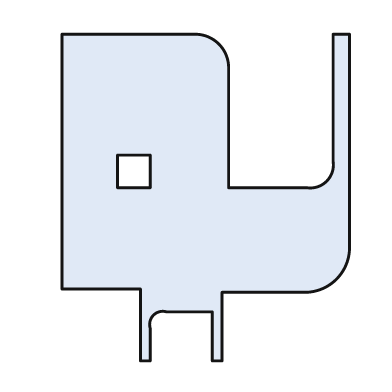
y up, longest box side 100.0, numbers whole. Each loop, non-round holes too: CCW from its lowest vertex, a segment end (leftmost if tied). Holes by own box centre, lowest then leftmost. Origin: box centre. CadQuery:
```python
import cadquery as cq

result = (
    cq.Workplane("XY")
    .moveTo(-20.0, -50.0)
    .lineTo(-17.0, -50.0)
    .lineTo(-17.0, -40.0)
    .threePointArc((-16.0, -36.0), (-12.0, -35.0))
    .lineTo(2.0, -35.0)
    .lineTo(2.0, -50.0)
    .lineTo(5.0, -50.0)
    .lineTo(5.0, -29.0)
    .lineTo(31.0, -29.0)
    .threePointArc((40.0, -25.0), (44.0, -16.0))
    .lineTo(44.0, 50.0)
    .lineTo(39.0, 50.0)
    .lineTo(39.0, 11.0)
    .threePointArc((37.0, 5.0), (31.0, 3.0))
    .lineTo(7.0, 3.0)
    .lineTo(7.0, 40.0)
    .threePointArc((4.0, 47.0), (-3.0, 50.0))
    .lineTo(-44.0, 50.0)
    .lineTo(-44.0, -28.0)
    .lineTo(-20.0, -28.0)
    .close()
    .moveTo(-27.0, 3.0)
    .lineTo(-17.0, 3.0)
    .lineTo(-17.0, 13.0)
    .lineTo(-27.0, 13.0)
    .close()
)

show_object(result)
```